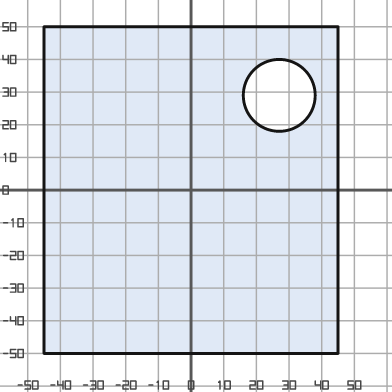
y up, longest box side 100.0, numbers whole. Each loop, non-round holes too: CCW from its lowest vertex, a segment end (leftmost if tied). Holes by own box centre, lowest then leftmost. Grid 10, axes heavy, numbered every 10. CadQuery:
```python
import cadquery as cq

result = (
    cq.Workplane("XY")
    .moveTo(-45.0, -50.0)
    .lineTo(45.0, -50.0)
    .lineTo(45.0, 50.0)
    .lineTo(-45.0, 50.0)
    .close()
    .moveTo(27.0, 29.0)
    .circle(11.0)
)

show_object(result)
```